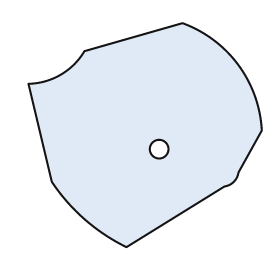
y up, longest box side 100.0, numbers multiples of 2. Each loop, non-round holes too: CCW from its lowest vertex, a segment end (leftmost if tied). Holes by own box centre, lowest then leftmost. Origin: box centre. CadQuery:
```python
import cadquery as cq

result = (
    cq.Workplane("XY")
    .moveTo(-8.0, -48.0)
    .lineTo(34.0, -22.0)
    .threePointArc((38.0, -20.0), (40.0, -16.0))
    .lineTo(50.0, 2.0)
    .threePointArc((40.0, 30.0), (16.0, 48.0))
    .lineTo(-26.0, 36.0)
    .threePointArc((-36.0, 26.0), (-50.0, 22.0))
    .lineTo(-40.0, -20.0)
    .threePointArc((-26.0, -36.0), (-8.0, -48.0))
    .close()
    .moveTo(6.0, -6.0)
    .circle(4.0)
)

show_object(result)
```